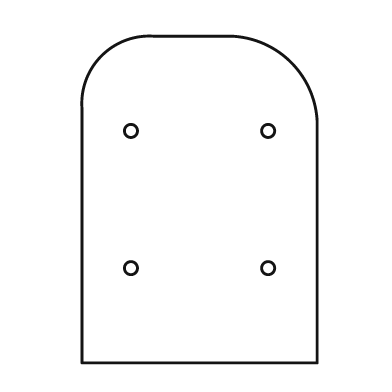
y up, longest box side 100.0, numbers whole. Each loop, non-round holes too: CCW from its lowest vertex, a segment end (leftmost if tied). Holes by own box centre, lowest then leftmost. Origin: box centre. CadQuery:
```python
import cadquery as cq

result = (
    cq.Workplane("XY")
    .moveTo(-36.0, -50.0)
    .lineTo(36.0, -50.0)
    .lineTo(36.0, 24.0)
    .threePointArc((28.0, 42.0), (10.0, 50.0))
    .lineTo(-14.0, 50.0)
    .threePointArc((-30.0, 44.0), (-36.0, 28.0))
    .close()
    .moveTo(-21.0, -21.0)
    .circle(2.0)
    .moveTo(21.0, -21.0)
    .circle(2.0)
    .moveTo(-21.0, 21.0)
    .circle(2.0)
    .moveTo(21.0, 21.0)
    .circle(2.0)
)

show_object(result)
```